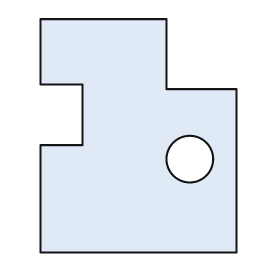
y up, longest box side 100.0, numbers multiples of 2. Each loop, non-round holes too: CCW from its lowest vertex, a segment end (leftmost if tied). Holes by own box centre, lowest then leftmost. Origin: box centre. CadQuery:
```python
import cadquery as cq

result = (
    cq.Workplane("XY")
    .moveTo(-42.0, -50.0)
    .lineTo(42.0, -50.0)
    .lineTo(42.0, 20.0)
    .lineTo(12.0, 20.0)
    .lineTo(12.0, 50.0)
    .lineTo(-42.0, 50.0)
    .lineTo(-42.0, 22.0)
    .lineTo(-24.0, 22.0)
    .lineTo(-24.0, -4.0)
    .lineTo(-42.0, -4.0)
    .close()
    .moveTo(22.0, -10.0)
    .circle(10.0)
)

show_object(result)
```